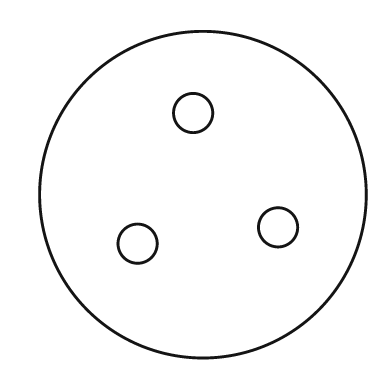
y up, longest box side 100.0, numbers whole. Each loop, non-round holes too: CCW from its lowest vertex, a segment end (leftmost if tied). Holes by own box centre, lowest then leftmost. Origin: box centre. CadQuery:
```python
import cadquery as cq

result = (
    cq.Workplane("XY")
    .moveTo(0.0, 0.0)
    .circle(50.0)
    .moveTo(-20.0, -15.0)
    .circle(6.0)
    .moveTo(23.0, -10.0)
    .circle(6.0)
    .moveTo(-3.0, 25.0)
    .circle(6.0)
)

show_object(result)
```